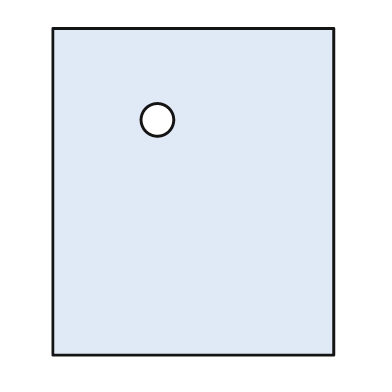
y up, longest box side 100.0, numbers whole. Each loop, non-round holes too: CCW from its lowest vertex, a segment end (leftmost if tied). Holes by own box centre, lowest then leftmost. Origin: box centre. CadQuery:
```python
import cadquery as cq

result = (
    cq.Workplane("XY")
    .moveTo(-43.0, -50.0)
    .lineTo(43.0, -50.0)
    .lineTo(43.0, 50.0)
    .lineTo(-43.0, 50.0)
    .close()
    .moveTo(-11.0, 22.0)
    .circle(5.0)
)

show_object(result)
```